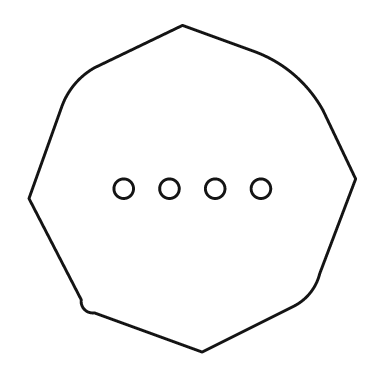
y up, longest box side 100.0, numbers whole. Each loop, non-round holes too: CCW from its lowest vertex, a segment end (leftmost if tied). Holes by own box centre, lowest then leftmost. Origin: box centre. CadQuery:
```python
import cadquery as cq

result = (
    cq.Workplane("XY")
    .moveTo(3.0, -50.0)
    .lineTo(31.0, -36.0)
    .threePointArc((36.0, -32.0), (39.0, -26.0))
    .lineTo(50.0, 3.0)
    .lineTo(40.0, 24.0)
    .threePointArc((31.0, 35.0), (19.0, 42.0))
    .lineTo(-3.0, 50.0)
    .lineTo(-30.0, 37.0)
    .threePointArc((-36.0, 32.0), (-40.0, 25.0))
    .lineTo(-50.0, -3.0)
    .lineTo(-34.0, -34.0)
    .threePointArc((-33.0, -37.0), (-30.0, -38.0))
    .close()
    .moveTo(-21.0, 0.0)
    .circle(3.0)
    .moveTo(-7.0, 0.0)
    .circle(3.0)
    .moveTo(7.0, 0.0)
    .circle(3.0)
    .moveTo(21.0, 0.0)
    .circle(3.0)
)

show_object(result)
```